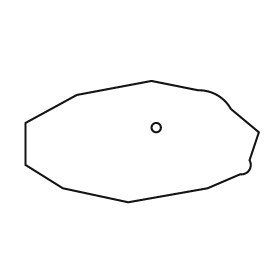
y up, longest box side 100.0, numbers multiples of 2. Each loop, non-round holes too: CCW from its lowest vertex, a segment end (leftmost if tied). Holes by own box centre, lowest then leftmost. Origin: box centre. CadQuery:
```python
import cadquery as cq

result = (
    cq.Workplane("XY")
    .moveTo(-6.0, -26.0)
    .lineTo(28.0, -20.0)
    .lineTo(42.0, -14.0)
    .threePointArc((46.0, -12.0), (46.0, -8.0))
    .lineTo(50.0, 4.0)
    .lineTo(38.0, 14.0)
    .threePointArc((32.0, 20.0), (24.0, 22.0))
    .lineTo(4.0, 26.0)
    .lineTo(-28.0, 20.0)
    .lineTo(-50.0, 8.0)
    .lineTo(-50.0, -10.0)
    .lineTo(-34.0, -20.0)
    .close()
    .moveTo(6.0, 6.0)
    .circle(2.0)
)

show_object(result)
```